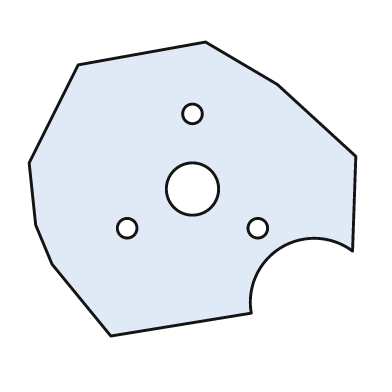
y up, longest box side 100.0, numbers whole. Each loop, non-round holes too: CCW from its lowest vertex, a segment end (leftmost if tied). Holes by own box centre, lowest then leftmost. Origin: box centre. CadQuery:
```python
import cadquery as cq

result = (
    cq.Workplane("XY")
    .moveTo(-25.0, -45.0)
    .lineTo(18.0, -38.0)
    .threePointArc((27.0, -18.0), (49.0, -19.0))
    .lineTo(50.0, 10.0)
    .lineTo(26.0, 32.0)
    .lineTo(4.0, 45.0)
    .lineTo(-35.0, 38.0)
    .lineTo(-50.0, 8.0)
    .lineTo(-48.0, -11.0)
    .lineTo(-43.0, -23.0)
    .close()
    .moveTo(-20.0, -12.0)
    .circle(3.0)
    .moveTo(20.0, -12.0)
    .circle(3.0)
    .moveTo(0.0, 0.0)
    .circle(8.0)
    .moveTo(0.0, 23.0)
    .circle(3.0)
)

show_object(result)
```